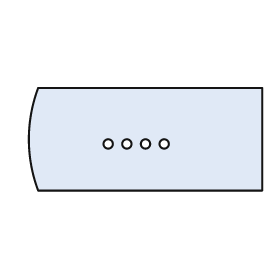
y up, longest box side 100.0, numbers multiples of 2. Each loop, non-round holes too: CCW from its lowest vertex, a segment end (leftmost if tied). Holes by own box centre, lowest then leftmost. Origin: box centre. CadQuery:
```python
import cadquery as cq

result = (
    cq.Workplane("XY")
    .moveTo(-46.0, -22.0)
    .lineTo(50.0, -22.0)
    .lineTo(50.0, 22.0)
    .lineTo(-46.0, 22.0)
    .threePointArc((-50.0, 0.0), (-46.0, -22.0))
    .close()
    .moveTo(-16.0, -2.0)
    .circle(2.0)
    .moveTo(-8.0, -2.0)
    .circle(2.0)
    .moveTo(0.0, -2.0)
    .circle(2.0)
    .moveTo(8.0, -2.0)
    .circle(2.0)
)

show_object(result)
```